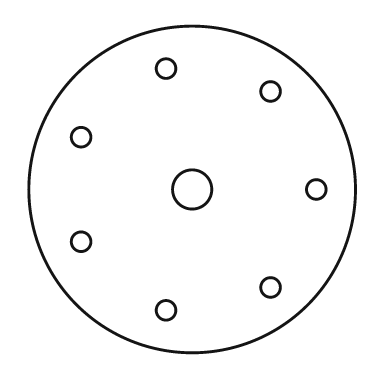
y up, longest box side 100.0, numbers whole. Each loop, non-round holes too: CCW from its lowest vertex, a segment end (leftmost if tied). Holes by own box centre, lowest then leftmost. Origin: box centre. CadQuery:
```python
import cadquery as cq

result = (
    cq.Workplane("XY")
    .moveTo(0.0, 0.0)
    .circle(50.0)
    .moveTo(-8.0, -37.0)
    .circle(3.0)
    .moveTo(24.0, -30.0)
    .circle(3.0)
    .moveTo(-34.0, -16.0)
    .circle(3.0)
    .moveTo(0.0, 0.0)
    .circle(6.0)
    .moveTo(38.0, 0.0)
    .circle(3.0)
    .moveTo(-34.0, 16.0)
    .circle(3.0)
    .moveTo(24.0, 30.0)
    .circle(3.0)
    .moveTo(-8.0, 37.0)
    .circle(3.0)
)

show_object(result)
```